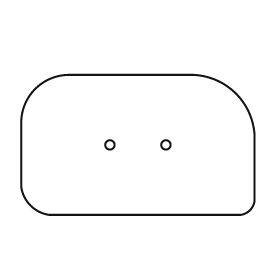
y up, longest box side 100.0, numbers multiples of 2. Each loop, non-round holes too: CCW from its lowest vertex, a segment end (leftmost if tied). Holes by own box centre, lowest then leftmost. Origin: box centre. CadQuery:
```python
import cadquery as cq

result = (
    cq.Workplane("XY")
    .moveTo(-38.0, -30.0)
    .lineTo(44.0, -30.0)
    .threePointArc((48.0, -28.0), (50.0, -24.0))
    .lineTo(50.0, 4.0)
    .threePointArc((42.0, 22.0), (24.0, 30.0))
    .lineTo(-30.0, 30.0)
    .threePointArc((-44.0, 24.0), (-50.0, 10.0))
    .lineTo(-50.0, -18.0)
    .threePointArc((-46.0, -26.0), (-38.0, -30.0))
    .close()
    .moveTo(-12.0, 0.0)
    .circle(2.0)
    .moveTo(12.0, 0.0)
    .circle(2.0)
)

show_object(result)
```